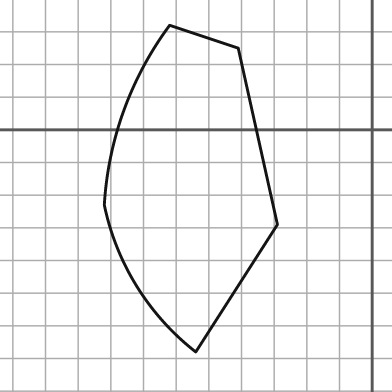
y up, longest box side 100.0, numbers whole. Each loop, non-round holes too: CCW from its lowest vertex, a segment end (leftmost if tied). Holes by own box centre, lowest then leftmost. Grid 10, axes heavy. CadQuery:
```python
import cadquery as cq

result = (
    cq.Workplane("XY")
    .moveTo(-54.0, -68.0)
    .lineTo(-29.0, -29.0)
    .lineTo(-41.0, 25.0)
    .lineTo(-62.0, 32.0)
    .threePointArc((-76.0, 6.0), (-82.0, -23.0))
    .threePointArc((-72.0, -48.0), (-54.0, -68.0))
    .close()
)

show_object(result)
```